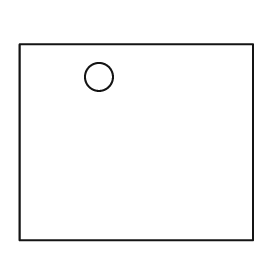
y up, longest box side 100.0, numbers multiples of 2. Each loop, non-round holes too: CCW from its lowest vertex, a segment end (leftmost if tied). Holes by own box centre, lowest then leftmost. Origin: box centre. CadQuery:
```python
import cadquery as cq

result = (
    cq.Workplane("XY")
    .moveTo(-50.0, -42.0)
    .lineTo(50.0, -42.0)
    .lineTo(50.0, 42.0)
    .lineTo(-50.0, 42.0)
    .close()
    .moveTo(-16.0, 28.0)
    .circle(6.0)
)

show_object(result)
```